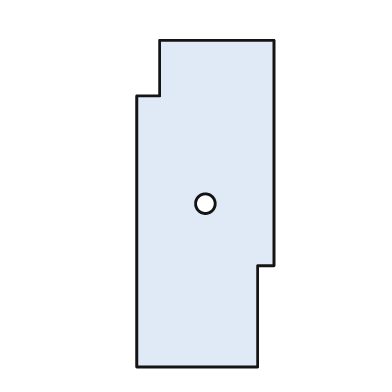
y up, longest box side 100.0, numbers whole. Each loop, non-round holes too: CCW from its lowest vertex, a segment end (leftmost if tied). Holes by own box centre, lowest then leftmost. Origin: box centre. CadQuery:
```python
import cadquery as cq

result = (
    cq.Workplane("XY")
    .moveTo(-21.0, -50.0)
    .lineTo(16.0, -50.0)
    .lineTo(16.0, -19.0)
    .lineTo(21.0, -19.0)
    .lineTo(21.0, 50.0)
    .lineTo(-14.0, 50.0)
    .lineTo(-14.0, 33.0)
    .lineTo(-21.0, 33.0)
    .close()
    .moveTo(0.0, 0.0)
    .circle(3.0)
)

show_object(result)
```